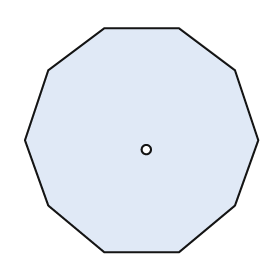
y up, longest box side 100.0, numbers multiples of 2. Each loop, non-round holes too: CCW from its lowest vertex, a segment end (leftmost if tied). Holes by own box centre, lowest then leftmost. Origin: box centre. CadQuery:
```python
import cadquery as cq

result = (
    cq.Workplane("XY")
    .moveTo(-16.0, -48.0)
    .lineTo(16.0, -48.0)
    .lineTo(40.0, -28.0)
    .lineTo(50.0, 0.0)
    .lineTo(40.0, 30.0)
    .lineTo(16.0, 48.0)
    .lineTo(-16.0, 48.0)
    .lineTo(-40.0, 30.0)
    .lineTo(-50.0, 0.0)
    .lineTo(-40.0, -28.0)
    .close()
    .moveTo(2.0, -4.0)
    .circle(2.0)
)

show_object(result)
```